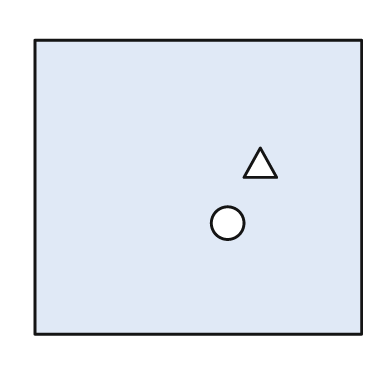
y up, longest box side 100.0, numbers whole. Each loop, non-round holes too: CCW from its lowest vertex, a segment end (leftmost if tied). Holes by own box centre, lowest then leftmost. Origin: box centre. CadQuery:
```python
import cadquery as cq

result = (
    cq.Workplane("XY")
    .moveTo(-50.0, -45.0)
    .lineTo(50.0, -45.0)
    .lineTo(50.0, 45.0)
    .lineTo(-50.0, 45.0)
    .close()
    .moveTo(9.0, -11.0)
    .circle(5.0)
    .moveTo(14.0, 3.0)
    .lineTo(24.0, 3.0)
    .lineTo(19.0, 12.0)
    .close()
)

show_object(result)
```